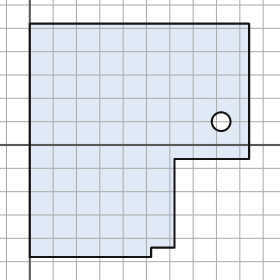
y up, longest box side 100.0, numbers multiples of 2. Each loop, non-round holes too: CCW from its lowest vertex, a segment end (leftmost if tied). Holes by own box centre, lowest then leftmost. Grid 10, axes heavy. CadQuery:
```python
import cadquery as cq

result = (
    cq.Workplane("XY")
    .moveTo(0.0, -48.0)
    .lineTo(52.0, -48.0)
    .lineTo(52.0, -44.0)
    .lineTo(62.0, -44.0)
    .lineTo(62.0, -6.0)
    .lineTo(94.0, -6.0)
    .lineTo(94.0, 52.0)
    .lineTo(0.0, 52.0)
    .close()
    .moveTo(82.0, 10.0)
    .circle(4.0)
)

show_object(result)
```